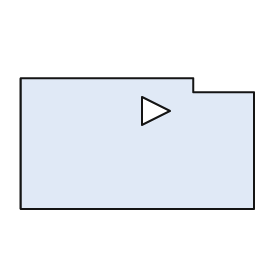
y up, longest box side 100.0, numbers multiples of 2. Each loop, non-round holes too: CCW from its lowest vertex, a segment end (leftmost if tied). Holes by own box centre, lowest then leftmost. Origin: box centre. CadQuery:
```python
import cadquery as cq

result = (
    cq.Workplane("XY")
    .moveTo(-50.0, -28.0)
    .lineTo(50.0, -28.0)
    .lineTo(50.0, 22.0)
    .lineTo(24.0, 22.0)
    .lineTo(24.0, 28.0)
    .lineTo(-50.0, 28.0)
    .close()
    .moveTo(2.0, 8.0)
    .lineTo(14.0, 14.0)
    .lineTo(2.0, 20.0)
    .close()
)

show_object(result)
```